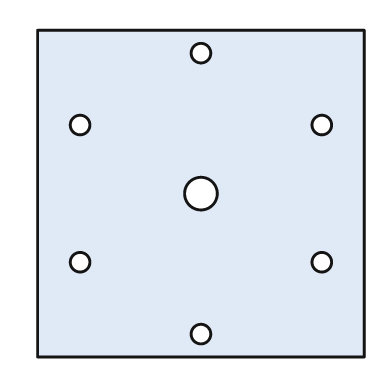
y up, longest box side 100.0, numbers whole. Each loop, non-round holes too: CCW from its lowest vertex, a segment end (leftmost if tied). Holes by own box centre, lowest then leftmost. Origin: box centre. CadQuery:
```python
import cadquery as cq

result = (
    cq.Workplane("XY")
    .moveTo(-50.0, -50.0)
    .lineTo(50.0, -50.0)
    .lineTo(50.0, 50.0)
    .lineTo(-50.0, 50.0)
    .close()
    .moveTo(0.0, -43.0)
    .circle(3.0)
    .moveTo(-37.0, -21.0)
    .circle(3.0)
    .moveTo(37.0, -21.0)
    .circle(3.0)
    .moveTo(0.0, 0.0)
    .circle(5.0)
    .moveTo(-37.0, 21.0)
    .circle(3.0)
    .moveTo(37.0, 21.0)
    .circle(3.0)
    .moveTo(0.0, 43.0)
    .circle(3.0)
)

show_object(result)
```